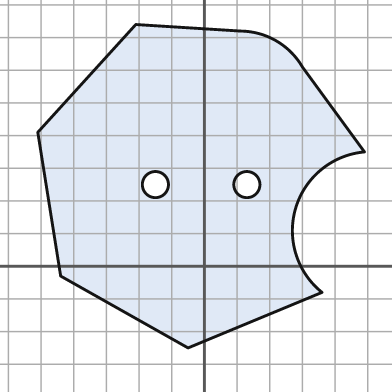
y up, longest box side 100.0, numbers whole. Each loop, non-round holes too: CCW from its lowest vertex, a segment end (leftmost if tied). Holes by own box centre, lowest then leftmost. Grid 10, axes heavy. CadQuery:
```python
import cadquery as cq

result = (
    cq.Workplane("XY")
    .moveTo(-5.0, -25.0)
    .lineTo(36.0, -8.0)
    .threePointArc((28.0, 18.0), (49.0, 35.0))
    .lineTo(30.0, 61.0)
    .threePointArc((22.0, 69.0), (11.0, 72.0))
    .lineTo(-21.0, 74.0)
    .lineTo(-51.0, 41.0)
    .lineTo(-44.0, -3.0)
    .close()
    .moveTo(-15.0, 25.0)
    .circle(4.0)
    .moveTo(13.0, 25.0)
    .circle(4.0)
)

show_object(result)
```